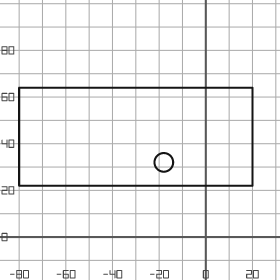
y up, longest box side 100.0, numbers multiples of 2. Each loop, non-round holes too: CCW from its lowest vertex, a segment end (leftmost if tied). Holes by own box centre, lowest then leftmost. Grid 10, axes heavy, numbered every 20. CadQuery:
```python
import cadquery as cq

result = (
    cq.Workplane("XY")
    .moveTo(-80.0, 22.0)
    .lineTo(20.0, 22.0)
    .lineTo(20.0, 64.0)
    .lineTo(-80.0, 64.0)
    .close()
    .moveTo(-18.0, 32.0)
    .circle(4.0)
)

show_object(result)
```